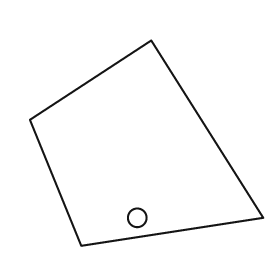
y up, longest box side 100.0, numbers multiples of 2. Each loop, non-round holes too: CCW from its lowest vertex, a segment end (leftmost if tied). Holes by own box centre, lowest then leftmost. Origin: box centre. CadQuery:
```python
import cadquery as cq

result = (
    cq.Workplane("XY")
    .moveTo(-28.0, -44.0)
    .lineTo(50.0, -32.0)
    .lineTo(2.0, 44.0)
    .lineTo(-50.0, 10.0)
    .close()
    .moveTo(-4.0, -32.0)
    .circle(4.0)
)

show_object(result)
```